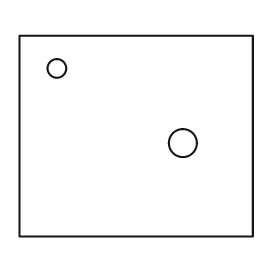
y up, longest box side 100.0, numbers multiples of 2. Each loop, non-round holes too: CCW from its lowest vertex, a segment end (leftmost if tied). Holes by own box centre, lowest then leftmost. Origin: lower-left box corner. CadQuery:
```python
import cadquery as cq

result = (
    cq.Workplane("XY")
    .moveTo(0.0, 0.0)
    .lineTo(100.0, 0.0)
    .lineTo(100.0, 86.0)
    .lineTo(0.0, 86.0)
    .close()
    .moveTo(70.0, 40.0)
    .circle(6.0)
    .moveTo(16.0, 72.0)
    .circle(4.0)
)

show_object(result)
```